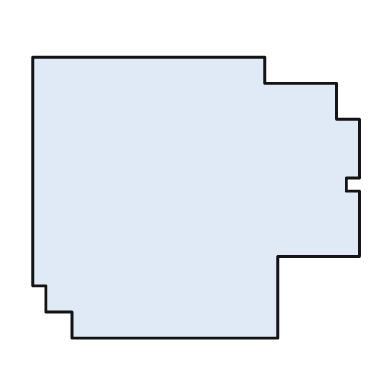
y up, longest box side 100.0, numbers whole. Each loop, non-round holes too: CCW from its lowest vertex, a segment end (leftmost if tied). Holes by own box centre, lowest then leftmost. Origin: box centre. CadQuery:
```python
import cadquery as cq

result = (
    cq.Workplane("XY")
    .moveTo(-38.0, -43.0)
    .lineTo(25.0, -43.0)
    .lineTo(25.0, -18.0)
    .lineTo(50.0, -18.0)
    .lineTo(50.0, 2.0)
    .lineTo(46.0, 2.0)
    .lineTo(46.0, 6.0)
    .lineTo(50.0, 6.0)
    .lineTo(50.0, 24.0)
    .lineTo(43.0, 24.0)
    .lineTo(43.0, 35.0)
    .lineTo(21.0, 35.0)
    .lineTo(21.0, 43.0)
    .lineTo(-50.0, 43.0)
    .lineTo(-50.0, -27.0)
    .lineTo(-46.0, -27.0)
    .lineTo(-46.0, -35.0)
    .lineTo(-38.0, -35.0)
    .close()
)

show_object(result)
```